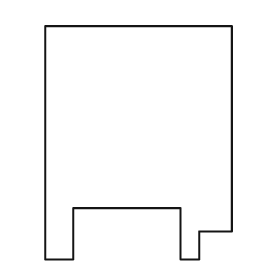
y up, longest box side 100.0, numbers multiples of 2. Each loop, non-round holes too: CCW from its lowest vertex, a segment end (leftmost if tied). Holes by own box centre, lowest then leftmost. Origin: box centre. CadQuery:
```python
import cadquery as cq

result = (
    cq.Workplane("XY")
    .moveTo(-40.0, -50.0)
    .lineTo(-28.0, -50.0)
    .lineTo(-28.0, -28.0)
    .lineTo(18.0, -28.0)
    .lineTo(18.0, -50.0)
    .lineTo(26.0, -50.0)
    .lineTo(26.0, -38.0)
    .lineTo(40.0, -38.0)
    .lineTo(40.0, 50.0)
    .lineTo(-40.0, 50.0)
    .close()
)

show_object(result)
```